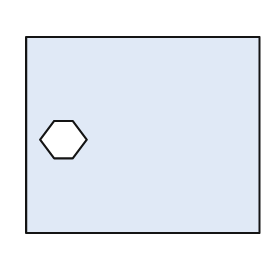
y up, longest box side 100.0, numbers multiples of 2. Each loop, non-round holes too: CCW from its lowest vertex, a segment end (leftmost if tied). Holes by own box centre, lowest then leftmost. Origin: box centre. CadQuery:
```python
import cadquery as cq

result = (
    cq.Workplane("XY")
    .moveTo(-50.0, -42.0)
    .lineTo(50.0, -42.0)
    .lineTo(50.0, 42.0)
    .lineTo(-50.0, 42.0)
    .close()
    .moveTo(-38.0, -10.0)
    .lineTo(-30.0, -10.0)
    .lineTo(-24.0, -2.0)
    .lineTo(-30.0, 6.0)
    .lineTo(-38.0, 6.0)
    .lineTo(-44.0, -2.0)
    .close()
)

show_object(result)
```